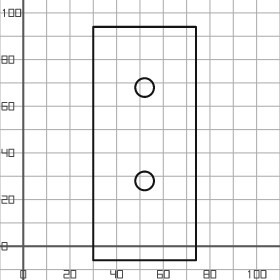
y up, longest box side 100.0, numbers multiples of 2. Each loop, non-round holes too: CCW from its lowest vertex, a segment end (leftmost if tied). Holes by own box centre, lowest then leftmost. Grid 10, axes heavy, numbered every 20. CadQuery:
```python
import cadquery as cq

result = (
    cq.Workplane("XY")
    .moveTo(30.0, -6.0)
    .lineTo(74.0, -6.0)
    .lineTo(74.0, 94.0)
    .lineTo(30.0, 94.0)
    .close()
    .moveTo(52.0, 28.0)
    .circle(4.0)
    .moveTo(52.0, 68.0)
    .circle(4.0)
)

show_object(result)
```